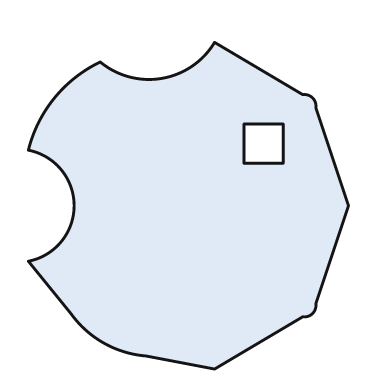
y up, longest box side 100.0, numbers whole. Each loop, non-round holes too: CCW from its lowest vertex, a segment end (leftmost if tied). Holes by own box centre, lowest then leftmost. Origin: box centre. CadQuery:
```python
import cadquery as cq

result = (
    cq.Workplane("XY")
    .moveTo(8.0, -50.0)
    .lineTo(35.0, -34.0)
    .threePointArc((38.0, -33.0), (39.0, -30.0))
    .lineTo(49.0, 0.0)
    .lineTo(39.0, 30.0)
    .threePointArc((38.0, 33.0), (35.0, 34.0))
    .lineTo(8.0, 50.0)
    .threePointArc((-8.0, 39.0), (-27.0, 44.0))
    .threePointArc((-41.0, 33.0), (-49.0, 17.0))
    .threePointArc((-35.0, 0.0), (-49.0, -17.0))
    .lineTo(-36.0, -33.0)
    .threePointArc((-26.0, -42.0), (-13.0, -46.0))
    .close()
    .moveTo(17.0, 13.0)
    .lineTo(29.0, 13.0)
    .lineTo(29.0, 25.0)
    .lineTo(17.0, 25.0)
    .close()
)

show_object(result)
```